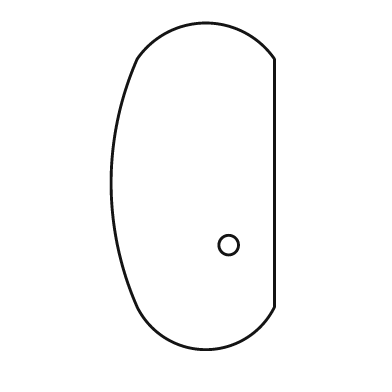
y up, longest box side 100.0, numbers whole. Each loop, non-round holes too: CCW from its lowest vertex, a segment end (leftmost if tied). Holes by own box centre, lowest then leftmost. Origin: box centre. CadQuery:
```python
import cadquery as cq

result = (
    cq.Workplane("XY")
    .moveTo(-17.0, -37.0)
    .threePointArc((4.0, -50.0), (25.0, -37.0))
    .lineTo(25.0, 39.0)
    .threePointArc((4.0, 50.0), (-17.0, 39.0))
    .threePointArc((-25.0, 1.0), (-17.0, -37.0))
    .close()
    .moveTo(11.0, -18.0)
    .circle(3.0)
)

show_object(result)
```